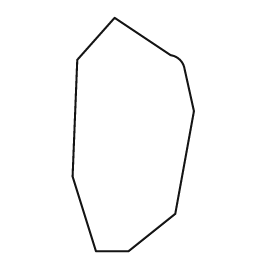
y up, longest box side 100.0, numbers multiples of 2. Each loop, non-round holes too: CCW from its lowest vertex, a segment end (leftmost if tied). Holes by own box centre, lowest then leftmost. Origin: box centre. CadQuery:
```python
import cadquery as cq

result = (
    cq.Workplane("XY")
    .moveTo(-16.0, -50.0)
    .lineTo(-2.0, -50.0)
    .lineTo(18.0, -34.0)
    .lineTo(26.0, 10.0)
    .lineTo(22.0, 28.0)
    .threePointArc((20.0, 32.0), (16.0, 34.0))
    .lineTo(-8.0, 50.0)
    .lineTo(-24.0, 32.0)
    .lineTo(-26.0, -18.0)
    .close()
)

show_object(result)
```